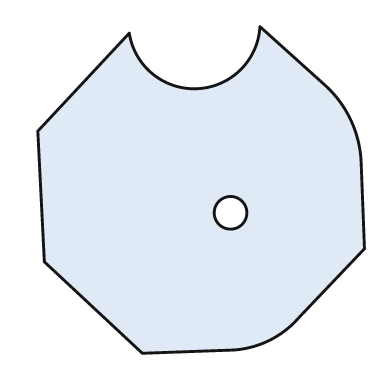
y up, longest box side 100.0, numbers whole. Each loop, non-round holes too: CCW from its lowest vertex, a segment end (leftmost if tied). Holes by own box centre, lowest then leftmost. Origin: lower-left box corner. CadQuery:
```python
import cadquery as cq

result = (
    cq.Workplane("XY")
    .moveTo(32.0, 0.0)
    .lineTo(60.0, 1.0)
    .threePointArc((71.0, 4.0), (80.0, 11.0))
    .lineTo(100.0, 32.0)
    .lineTo(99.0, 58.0)
    .threePointArc((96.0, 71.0), (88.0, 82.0))
    .lineTo(68.0, 100.0)
    .threePointArc((49.0, 81.0), (28.0, 98.0))
    .lineTo(0.0, 68.0)
    .lineTo(2.0, 28.0)
    .close()
    .moveTo(59.0, 43.0)
    .circle(5.0)
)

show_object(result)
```